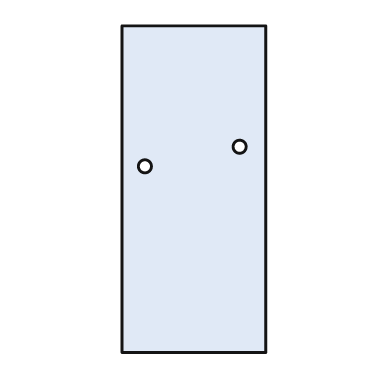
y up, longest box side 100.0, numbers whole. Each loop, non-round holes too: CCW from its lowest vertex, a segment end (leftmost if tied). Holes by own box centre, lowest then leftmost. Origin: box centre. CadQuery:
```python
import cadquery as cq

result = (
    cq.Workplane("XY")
    .moveTo(-22.0, -50.0)
    .lineTo(22.0, -50.0)
    .lineTo(22.0, 50.0)
    .lineTo(-22.0, 50.0)
    .close()
    .moveTo(-15.0, 7.0)
    .circle(2.0)
    .moveTo(14.0, 13.0)
    .circle(2.0)
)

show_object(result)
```